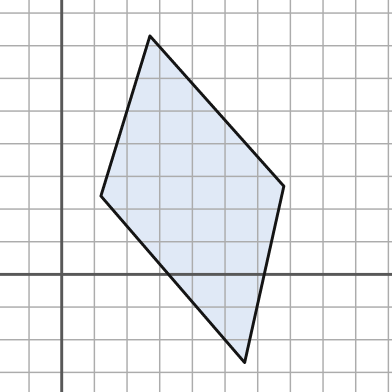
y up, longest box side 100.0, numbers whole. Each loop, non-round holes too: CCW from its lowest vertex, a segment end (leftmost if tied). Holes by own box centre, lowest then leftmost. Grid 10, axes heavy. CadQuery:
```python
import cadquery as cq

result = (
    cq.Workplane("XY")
    .moveTo(56.0, -27.0)
    .lineTo(68.0, 27.0)
    .lineTo(27.0, 73.0)
    .lineTo(12.0, 24.0)
    .close()
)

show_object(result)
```